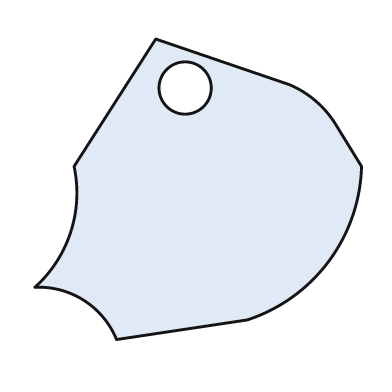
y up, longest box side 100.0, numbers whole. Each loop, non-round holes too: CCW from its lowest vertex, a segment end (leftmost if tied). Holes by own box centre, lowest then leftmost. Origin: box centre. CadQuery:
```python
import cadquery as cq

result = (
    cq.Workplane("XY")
    .moveTo(-25.0, -46.0)
    .lineTo(15.0, -40.0)
    .threePointArc((40.0, -22.0), (50.0, 7.0))
    .lineTo(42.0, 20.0)
    .threePointArc((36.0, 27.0), (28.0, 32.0))
    .lineTo(-13.0, 46.0)
    .lineTo(-38.0, 7.0)
    .threePointArc((-39.0, -13.0), (-50.0, -30.0))
    .threePointArc((-35.0, -34.0), (-25.0, -46.0))
    .close()
    .moveTo(-4.0, 31.0)
    .circle(8.0)
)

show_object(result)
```